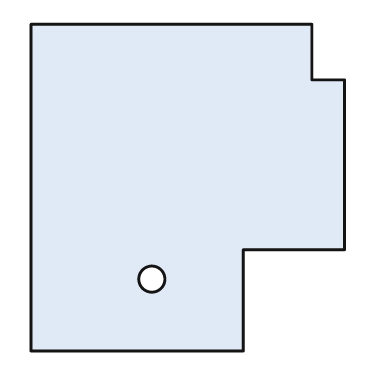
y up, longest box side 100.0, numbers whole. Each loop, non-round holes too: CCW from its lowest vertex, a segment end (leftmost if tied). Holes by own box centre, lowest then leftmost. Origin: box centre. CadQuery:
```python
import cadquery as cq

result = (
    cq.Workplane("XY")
    .moveTo(-48.0, -50.0)
    .lineTo(17.0, -50.0)
    .lineTo(17.0, -19.0)
    .lineTo(48.0, -19.0)
    .lineTo(48.0, 33.0)
    .lineTo(38.0, 33.0)
    .lineTo(38.0, 50.0)
    .lineTo(-48.0, 50.0)
    .close()
    .moveTo(-11.0, -28.0)
    .circle(4.0)
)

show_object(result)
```